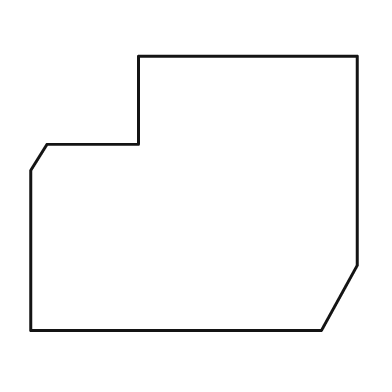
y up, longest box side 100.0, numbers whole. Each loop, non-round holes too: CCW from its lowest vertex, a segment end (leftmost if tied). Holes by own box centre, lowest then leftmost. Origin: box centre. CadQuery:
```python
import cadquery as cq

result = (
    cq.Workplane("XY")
    .moveTo(-50.0, -42.0)
    .lineTo(39.0, -42.0)
    .lineTo(50.0, -22.0)
    .lineTo(50.0, 42.0)
    .lineTo(-17.0, 42.0)
    .lineTo(-17.0, 15.0)
    .lineTo(-45.0, 15.0)
    .lineTo(-50.0, 7.0)
    .close()
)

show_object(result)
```